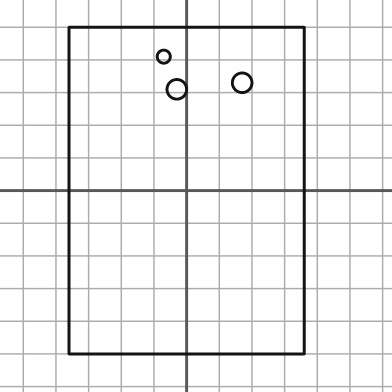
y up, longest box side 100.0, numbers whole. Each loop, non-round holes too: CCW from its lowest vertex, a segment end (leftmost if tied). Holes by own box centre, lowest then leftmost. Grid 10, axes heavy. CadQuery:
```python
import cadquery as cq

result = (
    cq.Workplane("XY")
    .moveTo(-36.0, -50.0)
    .lineTo(36.0, -50.0)
    .lineTo(36.0, 50.0)
    .lineTo(-36.0, 50.0)
    .close()
    .moveTo(-3.0, 31.0)
    .circle(3.0)
    .moveTo(17.0, 33.0)
    .circle(3.0)
    .moveTo(-7.0, 41.0)
    .circle(2.0)
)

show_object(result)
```